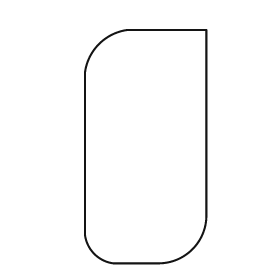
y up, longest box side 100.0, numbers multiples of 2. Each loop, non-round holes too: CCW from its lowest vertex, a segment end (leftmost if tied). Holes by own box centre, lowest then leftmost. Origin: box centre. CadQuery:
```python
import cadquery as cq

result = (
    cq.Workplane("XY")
    .moveTo(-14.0, -50.0)
    .lineTo(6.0, -50.0)
    .threePointArc((20.0, -44.0), (26.0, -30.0))
    .lineTo(26.0, 50.0)
    .lineTo(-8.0, 50.0)
    .threePointArc((-20.0, 44.0), (-26.0, 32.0))
    .lineTo(-26.0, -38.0)
    .threePointArc((-22.0, -46.0), (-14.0, -50.0))
    .close()
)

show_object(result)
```